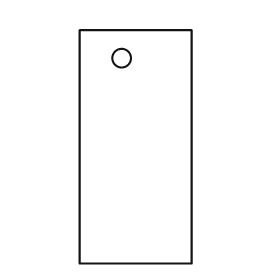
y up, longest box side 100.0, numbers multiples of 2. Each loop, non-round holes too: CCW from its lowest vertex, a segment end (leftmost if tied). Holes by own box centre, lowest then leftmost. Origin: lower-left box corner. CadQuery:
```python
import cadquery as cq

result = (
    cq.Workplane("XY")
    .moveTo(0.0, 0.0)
    .lineTo(48.0, 0.0)
    .lineTo(48.0, 100.0)
    .lineTo(0.0, 100.0)
    .close()
    .moveTo(18.0, 88.0)
    .circle(4.0)
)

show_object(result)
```